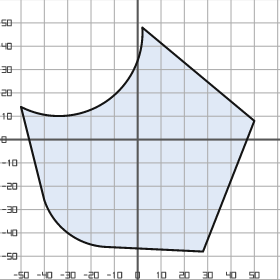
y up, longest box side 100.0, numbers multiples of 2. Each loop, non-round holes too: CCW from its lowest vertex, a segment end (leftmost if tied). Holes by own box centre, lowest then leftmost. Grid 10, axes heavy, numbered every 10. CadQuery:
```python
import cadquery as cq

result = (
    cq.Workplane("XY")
    .moveTo(28.0, -48.0)
    .lineTo(50.0, 8.0)
    .lineTo(2.0, 48.0)
    .threePointArc((-14.0, 16.0), (-50.0, 14.0))
    .lineTo(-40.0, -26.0)
    .threePointArc((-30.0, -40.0), (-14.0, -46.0))
    .close()
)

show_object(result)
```